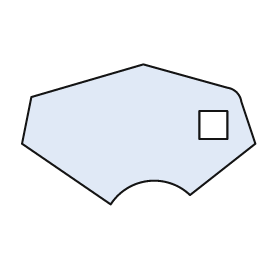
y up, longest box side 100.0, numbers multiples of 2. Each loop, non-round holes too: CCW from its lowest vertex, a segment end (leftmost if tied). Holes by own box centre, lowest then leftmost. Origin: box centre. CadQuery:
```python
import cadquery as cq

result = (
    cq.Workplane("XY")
    .moveTo(-12.0, -30.0)
    .threePointArc((4.0, -20.0), (22.0, -26.0))
    .lineTo(50.0, -4.0)
    .lineTo(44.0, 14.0)
    .threePointArc((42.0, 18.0), (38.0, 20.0))
    .lineTo(2.0, 30.0)
    .lineTo(-46.0, 16.0)
    .lineTo(-50.0, -4.0)
    .close()
    .moveTo(26.0, -2.0)
    .lineTo(38.0, -2.0)
    .lineTo(38.0, 10.0)
    .lineTo(26.0, 10.0)
    .close()
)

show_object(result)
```